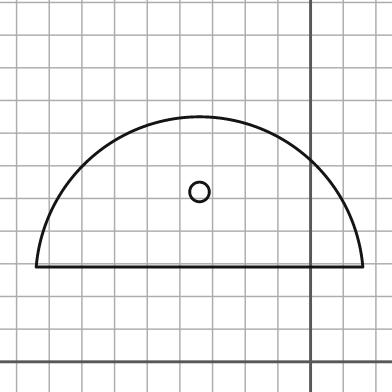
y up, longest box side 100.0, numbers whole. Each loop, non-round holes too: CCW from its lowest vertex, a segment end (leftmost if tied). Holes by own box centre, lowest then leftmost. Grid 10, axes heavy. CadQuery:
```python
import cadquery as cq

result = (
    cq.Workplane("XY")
    .moveTo(-84.0, 29.0)
    .lineTo(16.0, 29.0)
    .threePointArc((-34.0, 75.0), (-84.0, 29.0))
    .close()
    .moveTo(-34.0, 52.0)
    .circle(3.0)
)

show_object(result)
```